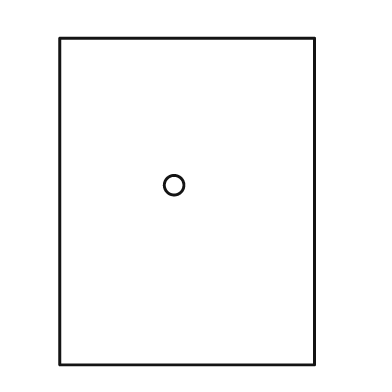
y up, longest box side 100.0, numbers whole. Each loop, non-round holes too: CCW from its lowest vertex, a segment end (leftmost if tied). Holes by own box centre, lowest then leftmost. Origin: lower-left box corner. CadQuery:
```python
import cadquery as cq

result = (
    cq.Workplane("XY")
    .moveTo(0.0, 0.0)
    .lineTo(78.0, 0.0)
    .lineTo(78.0, 100.0)
    .lineTo(0.0, 100.0)
    .close()
    .moveTo(35.0, 55.0)
    .circle(3.0)
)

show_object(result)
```